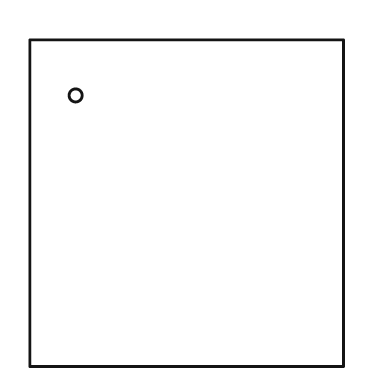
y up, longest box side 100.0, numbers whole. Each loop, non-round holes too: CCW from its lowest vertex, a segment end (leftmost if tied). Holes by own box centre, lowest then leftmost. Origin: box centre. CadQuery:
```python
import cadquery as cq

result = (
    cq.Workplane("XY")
    .moveTo(-48.0, -50.0)
    .lineTo(48.0, -50.0)
    .lineTo(48.0, 50.0)
    .lineTo(-48.0, 50.0)
    .close()
    .moveTo(-34.0, 33.0)
    .circle(2.0)
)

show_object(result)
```